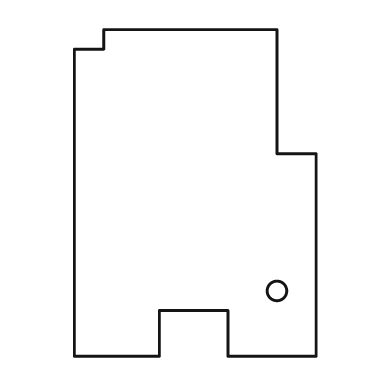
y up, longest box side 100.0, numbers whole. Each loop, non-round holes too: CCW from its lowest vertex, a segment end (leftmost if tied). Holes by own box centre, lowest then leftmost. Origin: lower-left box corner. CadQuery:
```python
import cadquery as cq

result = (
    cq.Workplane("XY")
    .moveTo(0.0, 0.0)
    .lineTo(26.0, 0.0)
    .lineTo(26.0, 14.0)
    .lineTo(47.0, 14.0)
    .lineTo(47.0, 0.0)
    .lineTo(74.0, 0.0)
    .lineTo(74.0, 62.0)
    .lineTo(62.0, 62.0)
    .lineTo(62.0, 100.0)
    .lineTo(9.0, 100.0)
    .lineTo(9.0, 94.0)
    .lineTo(0.0, 94.0)
    .close()
    .moveTo(62.0, 20.0)
    .circle(3.0)
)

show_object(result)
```